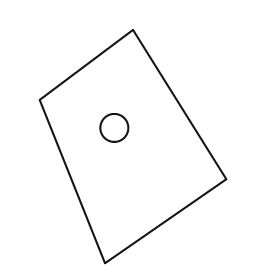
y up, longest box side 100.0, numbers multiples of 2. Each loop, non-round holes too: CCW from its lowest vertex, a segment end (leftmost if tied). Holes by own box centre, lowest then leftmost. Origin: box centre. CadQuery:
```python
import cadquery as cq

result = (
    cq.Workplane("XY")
    .moveTo(-12.0, -50.0)
    .lineTo(40.0, -14.0)
    .lineTo(0.0, 50.0)
    .lineTo(-40.0, 20.0)
    .close()
    .moveTo(-8.0, 8.0)
    .circle(6.0)
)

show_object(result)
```